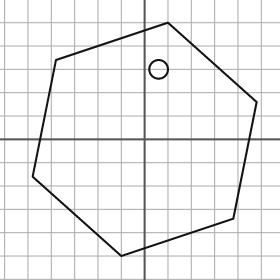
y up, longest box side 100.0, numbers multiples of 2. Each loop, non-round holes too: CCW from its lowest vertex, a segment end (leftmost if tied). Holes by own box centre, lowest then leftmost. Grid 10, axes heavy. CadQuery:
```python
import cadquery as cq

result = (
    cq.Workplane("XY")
    .moveTo(-10.0, -50.0)
    .lineTo(38.0, -34.0)
    .lineTo(48.0, 16.0)
    .lineTo(10.0, 50.0)
    .lineTo(-38.0, 34.0)
    .lineTo(-48.0, -16.0)
    .close()
    .moveTo(6.0, 30.0)
    .circle(4.0)
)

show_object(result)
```